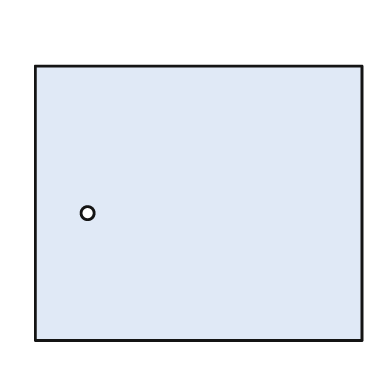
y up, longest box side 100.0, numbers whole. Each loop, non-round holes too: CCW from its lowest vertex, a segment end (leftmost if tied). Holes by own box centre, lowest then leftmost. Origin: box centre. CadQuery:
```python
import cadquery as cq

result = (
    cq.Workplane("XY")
    .moveTo(-50.0, -42.0)
    .lineTo(50.0, -42.0)
    .lineTo(50.0, 42.0)
    .lineTo(-50.0, 42.0)
    .close()
    .moveTo(-34.0, -3.0)
    .circle(2.0)
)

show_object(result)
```